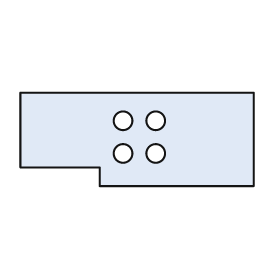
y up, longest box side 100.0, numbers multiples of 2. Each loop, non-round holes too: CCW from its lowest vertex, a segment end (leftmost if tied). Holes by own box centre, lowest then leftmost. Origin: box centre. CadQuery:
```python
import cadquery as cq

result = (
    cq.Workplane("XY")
    .moveTo(-16.0, -20.0)
    .lineTo(50.0, -20.0)
    .lineTo(50.0, 20.0)
    .lineTo(-50.0, 20.0)
    .lineTo(-50.0, -12.0)
    .lineTo(-16.0, -12.0)
    .close()
    .moveTo(-6.0, -6.0)
    .circle(4.0)
    .moveTo(8.0, -6.0)
    .circle(4.0)
    .moveTo(-6.0, 8.0)
    .circle(4.0)
    .moveTo(8.0, 8.0)
    .circle(4.0)
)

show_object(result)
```